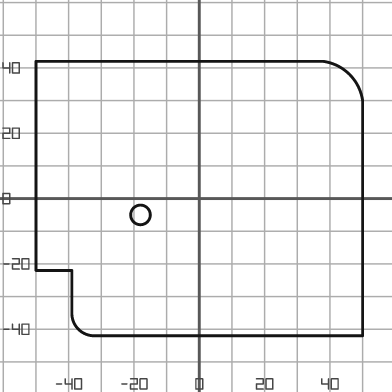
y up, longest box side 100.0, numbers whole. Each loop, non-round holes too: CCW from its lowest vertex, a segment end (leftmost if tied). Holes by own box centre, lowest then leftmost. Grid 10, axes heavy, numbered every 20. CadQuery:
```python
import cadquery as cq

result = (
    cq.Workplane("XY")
    .moveTo(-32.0, -42.0)
    .lineTo(50.0, -42.0)
    .lineTo(50.0, 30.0)
    .threePointArc((46.0, 38.0), (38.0, 42.0))
    .lineTo(-50.0, 42.0)
    .lineTo(-50.0, -22.0)
    .lineTo(-39.0, -22.0)
    .lineTo(-39.0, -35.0)
    .threePointArc((-37.0, -40.0), (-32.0, -42.0))
    .close()
    .moveTo(-18.0, -5.0)
    .circle(3.0)
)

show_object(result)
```